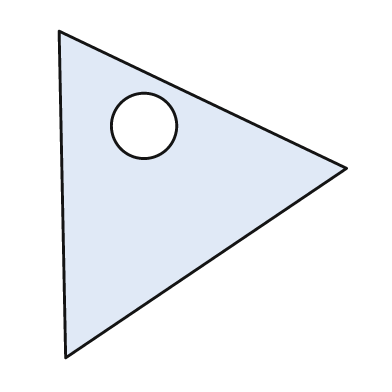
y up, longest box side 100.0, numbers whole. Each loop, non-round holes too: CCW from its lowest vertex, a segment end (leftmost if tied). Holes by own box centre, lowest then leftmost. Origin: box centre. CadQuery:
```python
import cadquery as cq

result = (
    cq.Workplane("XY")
    .moveTo(-42.0, -50.0)
    .lineTo(44.0, 8.0)
    .lineTo(-44.0, 50.0)
    .close()
    .moveTo(-18.0, 21.0)
    .circle(10.0)
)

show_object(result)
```